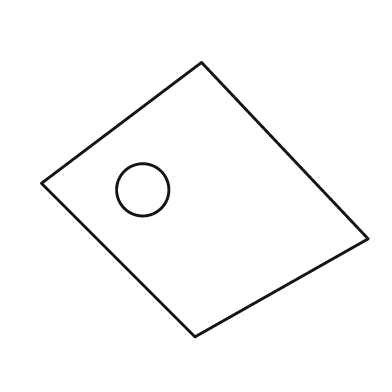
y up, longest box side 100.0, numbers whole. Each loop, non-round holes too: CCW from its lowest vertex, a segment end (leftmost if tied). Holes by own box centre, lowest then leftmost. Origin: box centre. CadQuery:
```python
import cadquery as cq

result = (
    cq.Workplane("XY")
    .moveTo(-3.0, -42.0)
    .lineTo(50.0, -12.0)
    .lineTo(-1.0, 42.0)
    .lineTo(-50.0, 5.0)
    .close()
    .moveTo(-19.0, 3.0)
    .circle(8.0)
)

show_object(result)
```